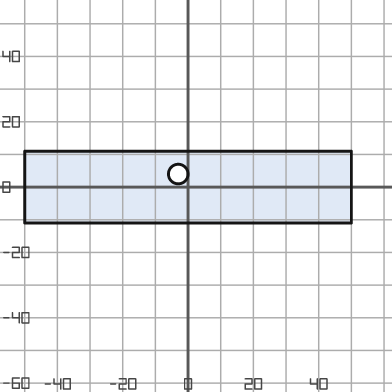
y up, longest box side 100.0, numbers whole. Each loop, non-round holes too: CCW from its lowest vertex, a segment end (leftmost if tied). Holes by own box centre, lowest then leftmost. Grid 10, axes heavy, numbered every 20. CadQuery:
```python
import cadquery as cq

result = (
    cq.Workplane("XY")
    .moveTo(-50.0, -11.0)
    .lineTo(50.0, -11.0)
    .lineTo(50.0, 11.0)
    .lineTo(-50.0, 11.0)
    .close()
    .moveTo(-3.0, 4.0)
    .circle(3.0)
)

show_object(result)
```